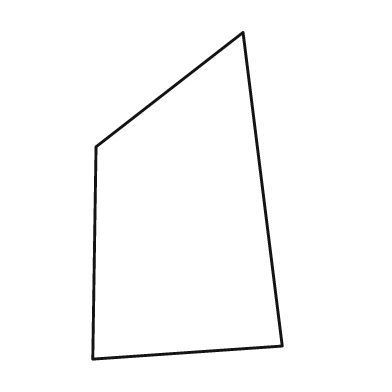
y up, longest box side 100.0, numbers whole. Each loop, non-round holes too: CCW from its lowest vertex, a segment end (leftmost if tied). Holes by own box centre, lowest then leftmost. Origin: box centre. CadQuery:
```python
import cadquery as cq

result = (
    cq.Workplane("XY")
    .moveTo(-29.0, -50.0)
    .lineTo(29.0, -46.0)
    .lineTo(17.0, 50.0)
    .lineTo(-28.0, 15.0)
    .close()
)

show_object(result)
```